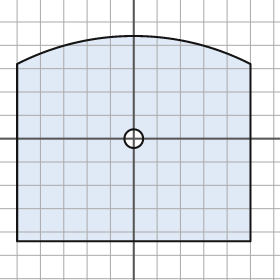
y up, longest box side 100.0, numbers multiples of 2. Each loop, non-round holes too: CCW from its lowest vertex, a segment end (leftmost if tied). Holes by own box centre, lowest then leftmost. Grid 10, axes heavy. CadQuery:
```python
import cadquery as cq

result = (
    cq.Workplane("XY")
    .moveTo(-50.0, -44.0)
    .lineTo(50.0, -44.0)
    .lineTo(50.0, 32.0)
    .threePointArc((0.0, 44.0), (-50.0, 32.0))
    .close()
    .moveTo(0.0, 0.0)
    .circle(4.0)
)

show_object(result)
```